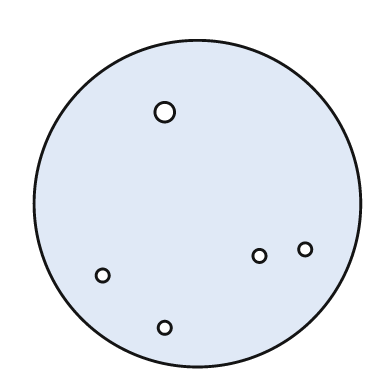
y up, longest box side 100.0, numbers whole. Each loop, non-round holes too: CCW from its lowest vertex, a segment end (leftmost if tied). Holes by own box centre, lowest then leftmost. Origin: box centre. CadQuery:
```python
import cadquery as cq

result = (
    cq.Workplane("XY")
    .moveTo(0.0, 0.0)
    .circle(50.0)
    .moveTo(-10.0, -38.0)
    .circle(2.0)
    .moveTo(-29.0, -22.0)
    .circle(2.0)
    .moveTo(19.0, -16.0)
    .circle(2.0)
    .moveTo(33.0, -14.0)
    .circle(2.0)
    .moveTo(-10.0, 28.0)
    .circle(3.0)
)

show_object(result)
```